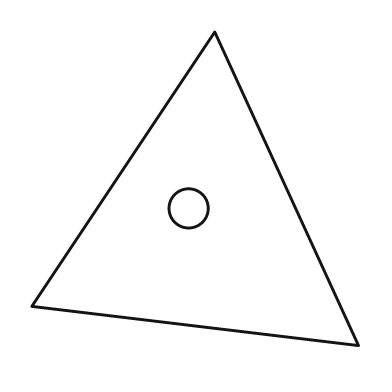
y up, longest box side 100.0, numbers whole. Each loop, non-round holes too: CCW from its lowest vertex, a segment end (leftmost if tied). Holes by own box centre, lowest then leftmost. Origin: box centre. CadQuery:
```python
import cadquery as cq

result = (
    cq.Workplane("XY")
    .moveTo(50.0, -48.0)
    .lineTo(6.0, 48.0)
    .lineTo(-50.0, -36.0)
    .close()
    .moveTo(-2.0, -6.0)
    .circle(6.0)
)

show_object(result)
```